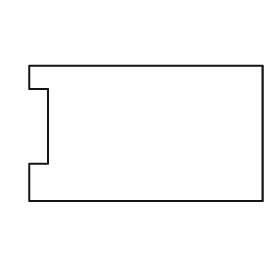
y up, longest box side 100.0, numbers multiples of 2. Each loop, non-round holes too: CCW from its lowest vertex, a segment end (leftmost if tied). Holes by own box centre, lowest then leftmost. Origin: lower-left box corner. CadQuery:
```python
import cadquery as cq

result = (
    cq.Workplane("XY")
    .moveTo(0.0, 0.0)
    .lineTo(100.0, 0.0)
    .lineTo(100.0, 58.0)
    .lineTo(0.0, 58.0)
    .lineTo(0.0, 48.0)
    .lineTo(8.0, 48.0)
    .lineTo(8.0, 16.0)
    .lineTo(0.0, 16.0)
    .close()
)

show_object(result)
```